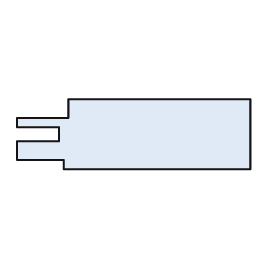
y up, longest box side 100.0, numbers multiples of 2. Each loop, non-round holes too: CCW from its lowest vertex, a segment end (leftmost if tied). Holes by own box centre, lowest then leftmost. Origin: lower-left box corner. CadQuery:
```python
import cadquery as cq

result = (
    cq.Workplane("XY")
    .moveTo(20.0, 0.0)
    .lineTo(100.0, 0.0)
    .lineTo(100.0, 30.0)
    .lineTo(22.0, 30.0)
    .lineTo(22.0, 22.0)
    .lineTo(0.0, 22.0)
    .lineTo(0.0, 18.0)
    .lineTo(18.0, 18.0)
    .lineTo(18.0, 12.0)
    .lineTo(0.0, 12.0)
    .lineTo(0.0, 4.0)
    .lineTo(20.0, 4.0)
    .close()
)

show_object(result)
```